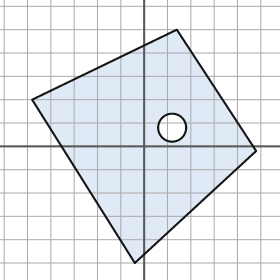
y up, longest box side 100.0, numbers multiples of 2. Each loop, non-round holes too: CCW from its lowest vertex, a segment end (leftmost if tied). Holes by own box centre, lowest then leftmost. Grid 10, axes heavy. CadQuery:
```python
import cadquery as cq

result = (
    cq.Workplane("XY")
    .moveTo(-4.0, -50.0)
    .lineTo(48.0, -2.0)
    .lineTo(14.0, 50.0)
    .lineTo(-48.0, 20.0)
    .close()
    .moveTo(12.0, 8.0)
    .circle(6.0)
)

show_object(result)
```